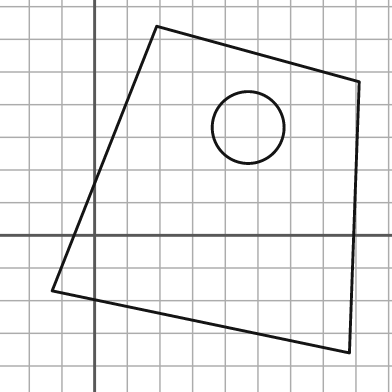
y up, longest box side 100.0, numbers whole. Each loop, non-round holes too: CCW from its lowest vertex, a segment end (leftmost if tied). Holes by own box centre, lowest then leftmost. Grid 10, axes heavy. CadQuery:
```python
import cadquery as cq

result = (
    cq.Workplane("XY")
    .moveTo(78.0, -36.0)
    .lineTo(81.0, 47.0)
    .lineTo(19.0, 64.0)
    .lineTo(-13.0, -17.0)
    .close()
    .moveTo(47.0, 33.0)
    .circle(11.0)
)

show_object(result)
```